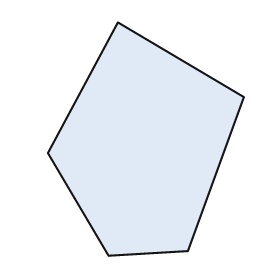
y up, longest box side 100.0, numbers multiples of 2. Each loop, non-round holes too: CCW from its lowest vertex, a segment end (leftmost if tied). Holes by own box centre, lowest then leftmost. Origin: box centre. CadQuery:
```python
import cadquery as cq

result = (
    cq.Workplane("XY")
    .moveTo(-16.0, -50.0)
    .lineTo(18.0, -48.0)
    .lineTo(42.0, 18.0)
    .lineTo(-12.0, 50.0)
    .lineTo(-42.0, -6.0)
    .close()
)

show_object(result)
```